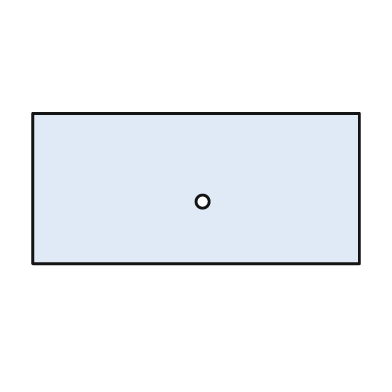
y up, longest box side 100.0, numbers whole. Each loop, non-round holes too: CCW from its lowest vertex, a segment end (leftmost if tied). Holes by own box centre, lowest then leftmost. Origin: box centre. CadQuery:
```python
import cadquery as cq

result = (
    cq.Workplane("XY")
    .moveTo(-50.0, -23.0)
    .lineTo(50.0, -23.0)
    .lineTo(50.0, 23.0)
    .lineTo(-50.0, 23.0)
    .close()
    .moveTo(2.0, -4.0)
    .circle(2.0)
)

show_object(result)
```